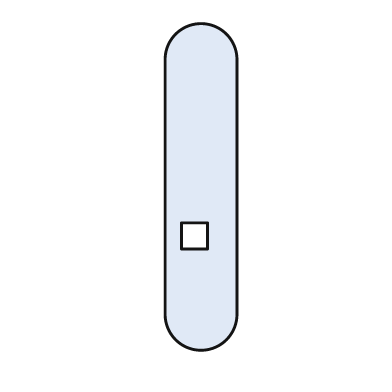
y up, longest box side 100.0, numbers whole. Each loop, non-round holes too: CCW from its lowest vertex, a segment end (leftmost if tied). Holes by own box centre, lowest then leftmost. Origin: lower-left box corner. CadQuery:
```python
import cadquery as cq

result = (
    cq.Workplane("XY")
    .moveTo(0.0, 11.0)
    .threePointArc((11.0, 0.0), (22.0, 11.0))
    .lineTo(22.0, 89.0)
    .threePointArc((11.0, 100.0), (0.0, 89.0))
    .close()
    .moveTo(5.0, 31.0)
    .lineTo(13.0, 31.0)
    .lineTo(13.0, 39.0)
    .lineTo(5.0, 39.0)
    .close()
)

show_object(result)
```